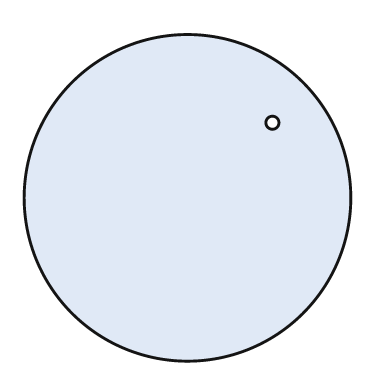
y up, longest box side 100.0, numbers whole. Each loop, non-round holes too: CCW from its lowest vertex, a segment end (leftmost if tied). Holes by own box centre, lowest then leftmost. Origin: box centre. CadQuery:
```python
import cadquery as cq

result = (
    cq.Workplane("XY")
    .moveTo(0.0, 0.0)
    .circle(50.0)
    .moveTo(26.0, 23.0)
    .circle(2.0)
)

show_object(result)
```